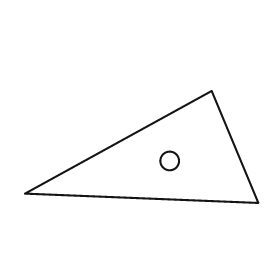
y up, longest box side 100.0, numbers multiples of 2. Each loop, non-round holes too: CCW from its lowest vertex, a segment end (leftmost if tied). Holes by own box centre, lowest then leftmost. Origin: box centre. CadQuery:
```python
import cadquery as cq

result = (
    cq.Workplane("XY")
    .moveTo(50.0, -24.0)
    .lineTo(30.0, 24.0)
    .lineTo(-50.0, -20.0)
    .close()
    .moveTo(12.0, -6.0)
    .circle(4.0)
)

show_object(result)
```